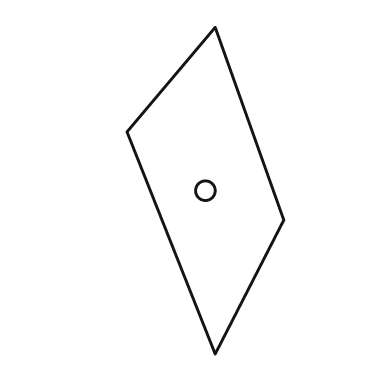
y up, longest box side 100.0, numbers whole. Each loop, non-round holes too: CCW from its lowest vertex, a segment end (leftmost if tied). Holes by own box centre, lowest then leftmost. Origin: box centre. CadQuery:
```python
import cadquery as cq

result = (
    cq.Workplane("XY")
    .moveTo(3.0, -50.0)
    .lineTo(24.0, -9.0)
    .lineTo(3.0, 50.0)
    .lineTo(-24.0, 18.0)
    .close()
    .moveTo(0.0, 0.0)
    .circle(3.0)
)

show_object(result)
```